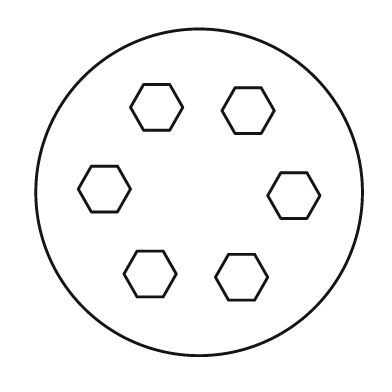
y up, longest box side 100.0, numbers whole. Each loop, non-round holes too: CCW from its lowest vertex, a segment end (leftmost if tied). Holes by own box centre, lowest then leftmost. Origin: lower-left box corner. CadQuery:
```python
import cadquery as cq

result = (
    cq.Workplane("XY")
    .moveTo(50.0, 50.0)
    .circle(50.0)
    .moveTo(59.0, 17.0)
    .lineTo(67.0, 17.0)
    .lineTo(71.0, 24.0)
    .lineTo(67.0, 31.0)
    .lineTo(59.0, 31.0)
    .lineTo(55.0, 24.0)
    .close()
    .moveTo(31.0, 18.0)
    .lineTo(39.0, 18.0)
    .lineTo(43.0, 25.0)
    .lineTo(39.0, 32.0)
    .lineTo(31.0, 32.0)
    .lineTo(27.0, 25.0)
    .close()
    .moveTo(75.0, 42.0)
    .lineTo(83.0, 42.0)
    .lineTo(87.0, 49.0)
    .lineTo(83.0, 56.0)
    .lineTo(75.0, 56.0)
    .lineTo(71.0, 49.0)
    .close()
    .moveTo(17.0, 44.0)
    .lineTo(25.0, 44.0)
    .lineTo(29.0, 51.0)
    .lineTo(25.0, 58.0)
    .lineTo(17.0, 58.0)
    .lineTo(13.0, 51.0)
    .close()
    .moveTo(61.0, 68.0)
    .lineTo(69.0, 68.0)
    .lineTo(73.0, 75.0)
    .lineTo(69.0, 82.0)
    .lineTo(61.0, 82.0)
    .lineTo(57.0, 75.0)
    .close()
    .moveTo(33.0, 69.0)
    .lineTo(41.0, 69.0)
    .lineTo(45.0, 76.0)
    .lineTo(41.0, 83.0)
    .lineTo(33.0, 83.0)
    .lineTo(29.0, 76.0)
    .close()
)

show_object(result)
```